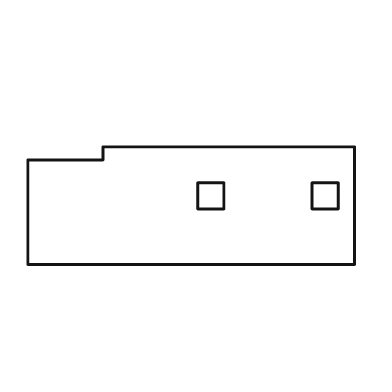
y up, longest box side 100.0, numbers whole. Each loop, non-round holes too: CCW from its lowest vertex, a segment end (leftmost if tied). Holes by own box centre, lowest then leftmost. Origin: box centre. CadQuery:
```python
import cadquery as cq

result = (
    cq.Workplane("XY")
    .moveTo(-50.0, -18.0)
    .lineTo(50.0, -18.0)
    .lineTo(50.0, 18.0)
    .lineTo(-27.0, 18.0)
    .lineTo(-27.0, 14.0)
    .lineTo(-50.0, 14.0)
    .close()
    .moveTo(2.0, -1.0)
    .lineTo(10.0, -1.0)
    .lineTo(10.0, 7.0)
    .lineTo(2.0, 7.0)
    .close()
    .moveTo(37.0, -1.0)
    .lineTo(45.0, -1.0)
    .lineTo(45.0, 7.0)
    .lineTo(37.0, 7.0)
    .close()
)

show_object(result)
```